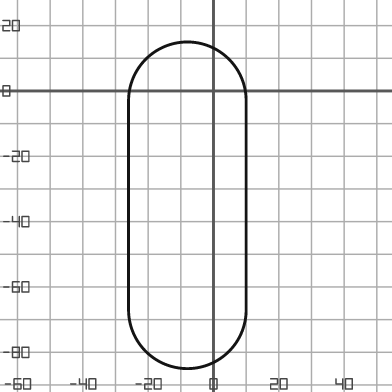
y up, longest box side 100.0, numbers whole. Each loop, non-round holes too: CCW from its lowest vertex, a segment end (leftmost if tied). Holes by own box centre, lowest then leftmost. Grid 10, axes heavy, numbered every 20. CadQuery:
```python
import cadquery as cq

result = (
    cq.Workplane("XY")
    .moveTo(-26.0, -67.0)
    .threePointArc((-8.0, -85.0), (10.0, -67.0))
    .lineTo(10.0, -3.0)
    .threePointArc((-8.0, 15.0), (-26.0, -3.0))
    .close()
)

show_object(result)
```